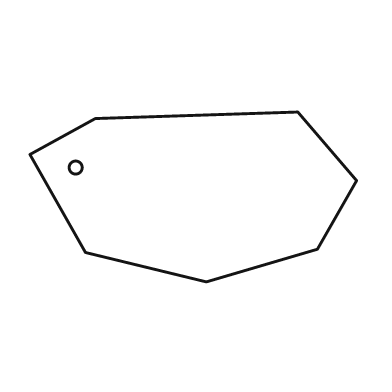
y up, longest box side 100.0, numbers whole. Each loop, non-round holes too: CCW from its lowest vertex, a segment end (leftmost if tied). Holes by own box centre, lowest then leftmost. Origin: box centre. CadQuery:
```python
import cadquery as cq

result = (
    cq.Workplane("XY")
    .moveTo(4.0, -26.0)
    .lineTo(38.0, -16.0)
    .lineTo(50.0, 5.0)
    .lineTo(32.0, 26.0)
    .lineTo(-30.0, 24.0)
    .lineTo(-50.0, 13.0)
    .lineTo(-33.0, -17.0)
    .close()
    .moveTo(-36.0, 9.0)
    .circle(2.0)
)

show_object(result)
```